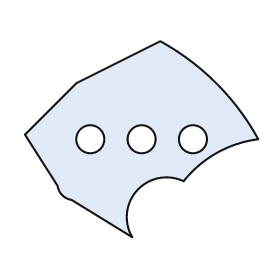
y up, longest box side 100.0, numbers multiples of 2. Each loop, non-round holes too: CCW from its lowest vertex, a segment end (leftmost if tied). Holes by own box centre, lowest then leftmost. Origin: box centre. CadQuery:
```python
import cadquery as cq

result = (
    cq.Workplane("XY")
    .moveTo(-4.0, -42.0)
    .threePointArc((-2.0, -22.0), (18.0, -18.0))
    .threePointArc((32.0, -6.0), (50.0, 0.0))
    .threePointArc((32.0, 24.0), (8.0, 42.0))
    .lineTo(-28.0, 24.0)
    .lineTo(-50.0, 2.0)
    .lineTo(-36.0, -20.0)
    .threePointArc((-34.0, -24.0), (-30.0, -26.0))
    .close()
    .moveTo(-22.0, 0.0)
    .circle(6.0)
    .moveTo(0.0, 0.0)
    .circle(6.0)
    .moveTo(22.0, 0.0)
    .circle(6.0)
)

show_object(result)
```